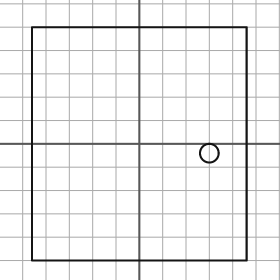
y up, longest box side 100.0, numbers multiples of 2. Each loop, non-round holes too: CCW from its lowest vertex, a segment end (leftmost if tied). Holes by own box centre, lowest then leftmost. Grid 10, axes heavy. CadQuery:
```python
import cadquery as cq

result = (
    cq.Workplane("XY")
    .moveTo(-46.0, -50.0)
    .lineTo(46.0, -50.0)
    .lineTo(46.0, 50.0)
    .lineTo(-46.0, 50.0)
    .close()
    .moveTo(30.0, -4.0)
    .circle(4.0)
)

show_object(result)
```